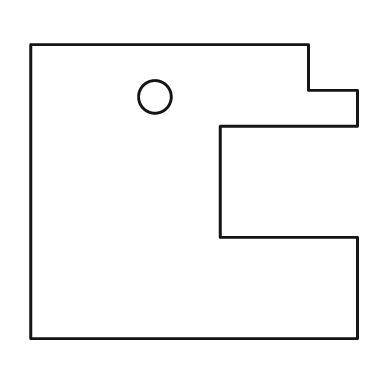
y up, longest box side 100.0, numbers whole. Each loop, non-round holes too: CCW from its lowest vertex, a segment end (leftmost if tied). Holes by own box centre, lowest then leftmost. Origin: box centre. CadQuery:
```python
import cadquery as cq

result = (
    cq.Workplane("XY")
    .moveTo(-50.0, -45.0)
    .lineTo(50.0, -45.0)
    .lineTo(50.0, -14.0)
    .lineTo(8.0, -14.0)
    .lineTo(8.0, 20.0)
    .lineTo(50.0, 20.0)
    .lineTo(50.0, 31.0)
    .lineTo(35.0, 31.0)
    .lineTo(35.0, 45.0)
    .lineTo(-50.0, 45.0)
    .close()
    .moveTo(-12.0, 29.0)
    .circle(5.0)
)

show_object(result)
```